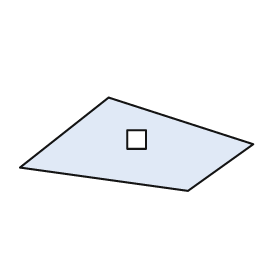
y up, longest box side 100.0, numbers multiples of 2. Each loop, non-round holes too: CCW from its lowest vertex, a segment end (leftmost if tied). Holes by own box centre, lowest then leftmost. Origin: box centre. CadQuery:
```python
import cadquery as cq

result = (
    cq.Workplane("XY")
    .moveTo(22.0, -20.0)
    .lineTo(50.0, 0.0)
    .lineTo(-12.0, 20.0)
    .lineTo(-50.0, -10.0)
    .close()
    .moveTo(-4.0, -2.0)
    .lineTo(4.0, -2.0)
    .lineTo(4.0, 6.0)
    .lineTo(-4.0, 6.0)
    .close()
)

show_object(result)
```